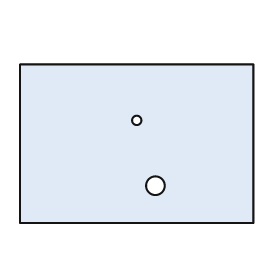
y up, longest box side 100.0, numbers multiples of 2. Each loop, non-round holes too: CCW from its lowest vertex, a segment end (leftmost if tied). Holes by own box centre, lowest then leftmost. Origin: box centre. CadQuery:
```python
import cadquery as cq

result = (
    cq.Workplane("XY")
    .moveTo(-50.0, -34.0)
    .lineTo(50.0, -34.0)
    .lineTo(50.0, 34.0)
    .lineTo(-50.0, 34.0)
    .close()
    .moveTo(8.0, -18.0)
    .circle(4.0)
    .moveTo(0.0, 10.0)
    .circle(2.0)
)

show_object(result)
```